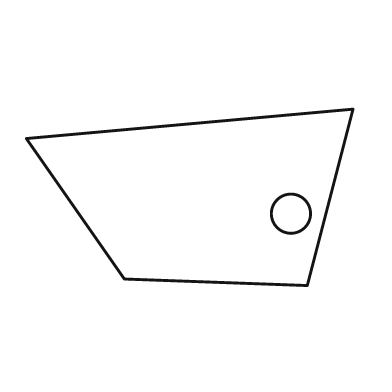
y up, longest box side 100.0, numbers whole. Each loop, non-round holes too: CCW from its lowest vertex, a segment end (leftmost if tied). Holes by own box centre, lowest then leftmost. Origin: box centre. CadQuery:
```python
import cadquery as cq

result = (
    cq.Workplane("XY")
    .moveTo(36.0, -27.0)
    .lineTo(50.0, 27.0)
    .lineTo(-50.0, 18.0)
    .lineTo(-20.0, -25.0)
    .close()
    .moveTo(31.0, -5.0)
    .circle(6.0)
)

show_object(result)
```